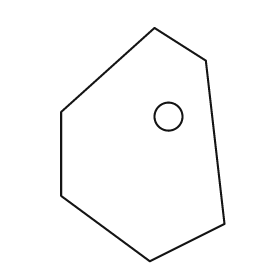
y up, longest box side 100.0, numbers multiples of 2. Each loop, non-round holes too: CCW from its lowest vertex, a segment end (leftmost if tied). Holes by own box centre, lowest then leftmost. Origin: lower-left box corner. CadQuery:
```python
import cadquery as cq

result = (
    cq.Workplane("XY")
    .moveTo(38.0, 0.0)
    .lineTo(70.0, 16.0)
    .lineTo(62.0, 86.0)
    .lineTo(40.0, 100.0)
    .lineTo(0.0, 64.0)
    .lineTo(0.0, 28.0)
    .close()
    .moveTo(46.0, 62.0)
    .circle(6.0)
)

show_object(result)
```